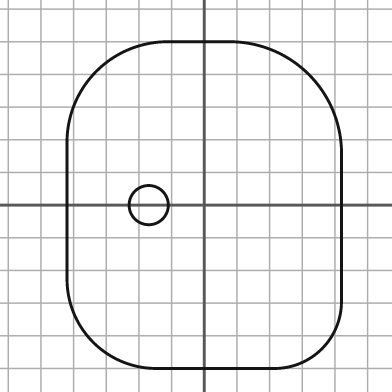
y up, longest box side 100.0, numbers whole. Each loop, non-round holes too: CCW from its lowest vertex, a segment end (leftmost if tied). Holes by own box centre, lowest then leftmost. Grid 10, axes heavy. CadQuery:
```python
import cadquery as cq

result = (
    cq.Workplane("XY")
    .moveTo(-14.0, -50.0)
    .lineTo(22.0, -50.0)
    .threePointArc((36.0, -44.0), (42.0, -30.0))
    .lineTo(42.0, 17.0)
    .threePointArc((32.0, 40.0), (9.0, 50.0))
    .lineTo(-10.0, 50.0)
    .threePointArc((-33.0, 41.0), (-42.0, 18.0))
    .lineTo(-42.0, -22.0)
    .threePointArc((-34.0, -42.0), (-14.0, -50.0))
    .close()
    .moveTo(-17.0, 0.0)
    .circle(6.0)
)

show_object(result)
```